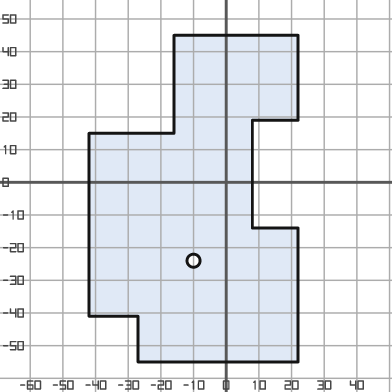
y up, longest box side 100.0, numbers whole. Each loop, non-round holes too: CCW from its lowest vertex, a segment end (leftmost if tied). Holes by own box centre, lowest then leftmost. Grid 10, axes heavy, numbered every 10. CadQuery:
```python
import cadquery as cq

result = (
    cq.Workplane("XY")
    .moveTo(-27.0, -55.0)
    .lineTo(22.0, -55.0)
    .lineTo(22.0, -14.0)
    .lineTo(8.0, -14.0)
    .lineTo(8.0, 19.0)
    .lineTo(22.0, 19.0)
    .lineTo(22.0, 45.0)
    .lineTo(-16.0, 45.0)
    .lineTo(-16.0, 15.0)
    .lineTo(-42.0, 15.0)
    .lineTo(-42.0, -41.0)
    .lineTo(-27.0, -41.0)
    .close()
    .moveTo(-10.0, -24.0)
    .circle(2.0)
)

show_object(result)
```